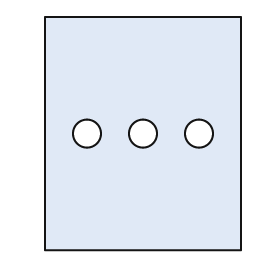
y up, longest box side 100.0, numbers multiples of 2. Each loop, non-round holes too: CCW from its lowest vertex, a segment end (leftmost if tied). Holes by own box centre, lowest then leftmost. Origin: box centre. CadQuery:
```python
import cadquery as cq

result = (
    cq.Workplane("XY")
    .moveTo(-42.0, -50.0)
    .lineTo(42.0, -50.0)
    .lineTo(42.0, 50.0)
    .lineTo(-42.0, 50.0)
    .close()
    .moveTo(-24.0, 0.0)
    .circle(6.0)
    .moveTo(0.0, 0.0)
    .circle(6.0)
    .moveTo(24.0, 0.0)
    .circle(6.0)
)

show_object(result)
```